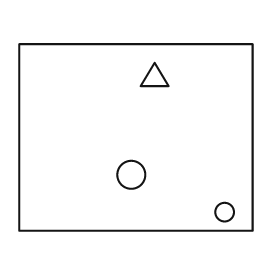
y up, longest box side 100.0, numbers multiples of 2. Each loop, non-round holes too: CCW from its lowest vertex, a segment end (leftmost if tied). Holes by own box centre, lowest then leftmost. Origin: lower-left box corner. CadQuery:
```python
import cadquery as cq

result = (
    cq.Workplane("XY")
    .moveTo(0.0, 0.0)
    .lineTo(100.0, 0.0)
    .lineTo(100.0, 80.0)
    .lineTo(0.0, 80.0)
    .close()
    .moveTo(88.0, 8.0)
    .circle(4.0)
    .moveTo(48.0, 24.0)
    .circle(6.0)
    .moveTo(52.0, 62.0)
    .lineTo(64.0, 62.0)
    .lineTo(58.0, 72.0)
    .close()
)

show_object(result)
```